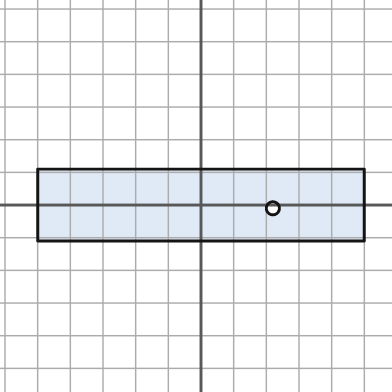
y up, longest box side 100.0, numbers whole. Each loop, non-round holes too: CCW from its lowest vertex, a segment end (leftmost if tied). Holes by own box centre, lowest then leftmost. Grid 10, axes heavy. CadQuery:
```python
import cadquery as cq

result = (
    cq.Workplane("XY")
    .moveTo(-50.0, -11.0)
    .lineTo(50.0, -11.0)
    .lineTo(50.0, 11.0)
    .lineTo(-50.0, 11.0)
    .close()
    .moveTo(22.0, -1.0)
    .circle(2.0)
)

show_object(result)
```